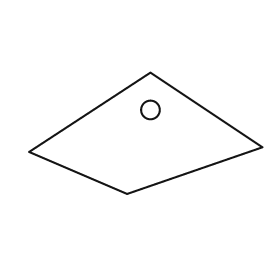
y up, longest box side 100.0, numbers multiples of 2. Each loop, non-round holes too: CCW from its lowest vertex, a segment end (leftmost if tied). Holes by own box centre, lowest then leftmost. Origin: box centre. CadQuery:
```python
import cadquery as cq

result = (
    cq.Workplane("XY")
    .moveTo(-8.0, -26.0)
    .lineTo(50.0, -6.0)
    .lineTo(2.0, 26.0)
    .lineTo(-50.0, -8.0)
    .close()
    .moveTo(2.0, 10.0)
    .circle(4.0)
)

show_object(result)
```